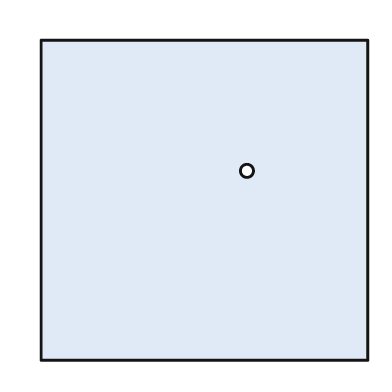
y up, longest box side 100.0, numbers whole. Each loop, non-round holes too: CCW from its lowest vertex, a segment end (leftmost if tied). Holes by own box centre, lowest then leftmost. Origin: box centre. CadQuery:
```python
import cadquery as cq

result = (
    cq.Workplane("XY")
    .moveTo(-50.0, -49.0)
    .lineTo(50.0, -49.0)
    .lineTo(50.0, 49.0)
    .lineTo(-50.0, 49.0)
    .close()
    .moveTo(13.0, 9.0)
    .circle(2.0)
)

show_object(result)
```